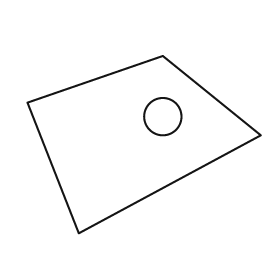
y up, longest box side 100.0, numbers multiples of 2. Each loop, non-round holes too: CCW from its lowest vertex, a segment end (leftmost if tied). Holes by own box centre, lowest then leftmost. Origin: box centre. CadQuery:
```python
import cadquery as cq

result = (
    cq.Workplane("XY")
    .moveTo(-28.0, -38.0)
    .lineTo(50.0, 4.0)
    .lineTo(8.0, 38.0)
    .lineTo(-50.0, 18.0)
    .close()
    .moveTo(8.0, 12.0)
    .circle(8.0)
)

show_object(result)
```